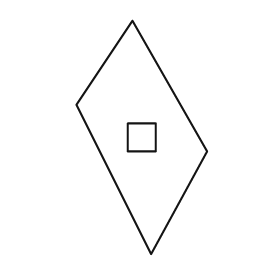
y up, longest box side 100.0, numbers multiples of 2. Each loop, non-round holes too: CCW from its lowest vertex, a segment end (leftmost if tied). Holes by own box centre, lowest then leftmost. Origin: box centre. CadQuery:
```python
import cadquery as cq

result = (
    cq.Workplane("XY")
    .moveTo(4.0, -50.0)
    .lineTo(28.0, -6.0)
    .lineTo(-4.0, 50.0)
    .lineTo(-28.0, 14.0)
    .close()
    .moveTo(-6.0, -6.0)
    .lineTo(6.0, -6.0)
    .lineTo(6.0, 6.0)
    .lineTo(-6.0, 6.0)
    .close()
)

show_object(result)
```